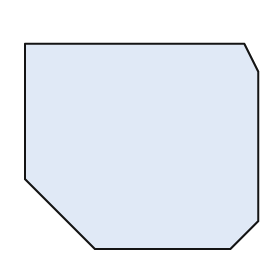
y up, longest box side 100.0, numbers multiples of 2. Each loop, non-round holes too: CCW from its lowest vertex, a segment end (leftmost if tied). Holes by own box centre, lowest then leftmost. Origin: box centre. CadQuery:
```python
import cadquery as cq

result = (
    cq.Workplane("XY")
    .moveTo(-20.0, -44.0)
    .lineTo(38.0, -44.0)
    .lineTo(50.0, -32.0)
    .lineTo(50.0, 32.0)
    .lineTo(44.0, 44.0)
    .lineTo(-50.0, 44.0)
    .lineTo(-50.0, -14.0)
    .close()
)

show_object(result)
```